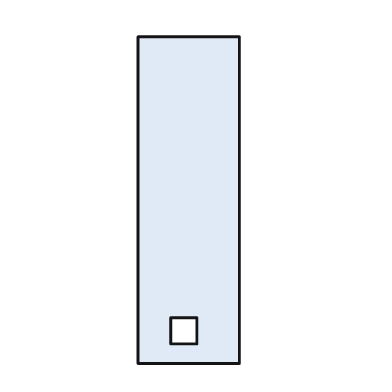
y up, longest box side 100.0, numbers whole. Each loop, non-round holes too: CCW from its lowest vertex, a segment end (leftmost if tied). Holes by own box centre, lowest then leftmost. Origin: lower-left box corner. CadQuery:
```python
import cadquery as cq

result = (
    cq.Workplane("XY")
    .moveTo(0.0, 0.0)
    .lineTo(31.0, 0.0)
    .lineTo(31.0, 100.0)
    .lineTo(0.0, 100.0)
    .close()
    .moveTo(10.0, 6.0)
    .lineTo(18.0, 6.0)
    .lineTo(18.0, 14.0)
    .lineTo(10.0, 14.0)
    .close()
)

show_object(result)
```